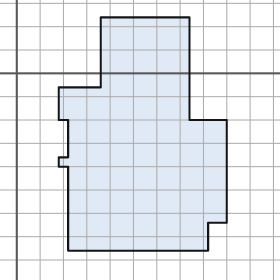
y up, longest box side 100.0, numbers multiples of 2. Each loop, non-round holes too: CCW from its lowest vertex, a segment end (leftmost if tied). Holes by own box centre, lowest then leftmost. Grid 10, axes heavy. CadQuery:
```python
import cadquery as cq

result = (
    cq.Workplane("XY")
    .moveTo(22.0, -76.0)
    .lineTo(82.0, -76.0)
    .lineTo(82.0, -64.0)
    .lineTo(90.0, -64.0)
    .lineTo(90.0, -20.0)
    .lineTo(74.0, -20.0)
    .lineTo(74.0, 24.0)
    .lineTo(36.0, 24.0)
    .lineTo(36.0, -6.0)
    .lineTo(18.0, -6.0)
    .lineTo(18.0, -20.0)
    .lineTo(22.0, -20.0)
    .lineTo(22.0, -36.0)
    .lineTo(18.0, -36.0)
    .lineTo(18.0, -40.0)
    .lineTo(22.0, -40.0)
    .close()
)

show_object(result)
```